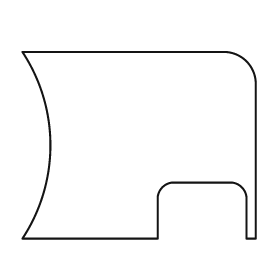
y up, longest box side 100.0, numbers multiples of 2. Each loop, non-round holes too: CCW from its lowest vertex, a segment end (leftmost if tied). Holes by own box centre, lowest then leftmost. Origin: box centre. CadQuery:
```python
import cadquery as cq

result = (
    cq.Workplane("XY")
    .moveTo(-50.0, -40.0)
    .lineTo(8.0, -40.0)
    .lineTo(8.0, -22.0)
    .threePointArc((10.0, -18.0), (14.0, -16.0))
    .lineTo(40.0, -16.0)
    .threePointArc((44.0, -18.0), (46.0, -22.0))
    .lineTo(46.0, -40.0)
    .lineTo(50.0, -40.0)
    .lineTo(50.0, 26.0)
    .threePointArc((46.0, 36.0), (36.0, 40.0))
    .lineTo(-50.0, 40.0)
    .threePointArc((-38.0, 0.0), (-50.0, -40.0))
    .close()
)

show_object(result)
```